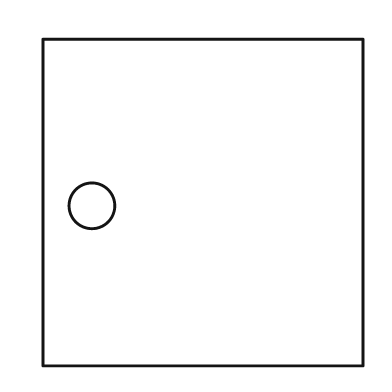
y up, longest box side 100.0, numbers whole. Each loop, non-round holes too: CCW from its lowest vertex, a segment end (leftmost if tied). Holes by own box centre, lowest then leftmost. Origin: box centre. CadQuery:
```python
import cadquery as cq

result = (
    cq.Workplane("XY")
    .moveTo(-49.0, -50.0)
    .lineTo(49.0, -50.0)
    .lineTo(49.0, 50.0)
    .lineTo(-49.0, 50.0)
    .close()
    .moveTo(-34.0, -1.0)
    .circle(7.0)
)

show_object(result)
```